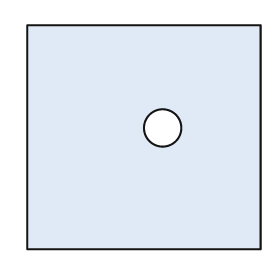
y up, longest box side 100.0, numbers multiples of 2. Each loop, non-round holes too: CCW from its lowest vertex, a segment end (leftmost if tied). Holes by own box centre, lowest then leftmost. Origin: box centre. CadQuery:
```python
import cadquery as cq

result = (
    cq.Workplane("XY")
    .moveTo(-50.0, -48.0)
    .lineTo(50.0, -48.0)
    .lineTo(50.0, 48.0)
    .lineTo(-50.0, 48.0)
    .close()
    .moveTo(8.0, 4.0)
    .circle(8.0)
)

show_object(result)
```